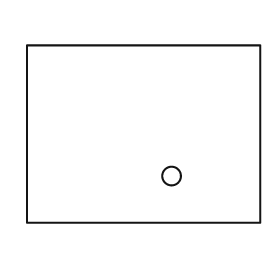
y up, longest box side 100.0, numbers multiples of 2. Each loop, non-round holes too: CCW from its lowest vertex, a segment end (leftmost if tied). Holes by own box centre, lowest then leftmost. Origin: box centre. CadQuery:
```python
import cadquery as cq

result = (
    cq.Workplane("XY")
    .moveTo(-50.0, -38.0)
    .lineTo(50.0, -38.0)
    .lineTo(50.0, 38.0)
    .lineTo(-50.0, 38.0)
    .close()
    .moveTo(12.0, -18.0)
    .circle(4.0)
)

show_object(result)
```